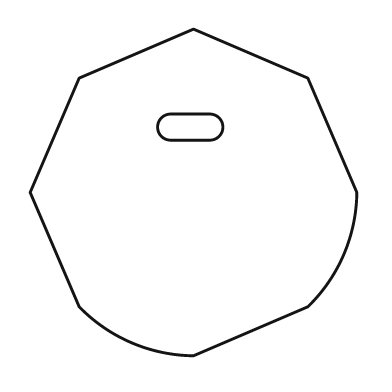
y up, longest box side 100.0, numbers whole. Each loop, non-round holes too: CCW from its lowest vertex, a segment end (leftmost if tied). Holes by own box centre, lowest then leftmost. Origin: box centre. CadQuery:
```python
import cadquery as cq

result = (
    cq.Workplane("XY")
    .moveTo(0.0, -50.0)
    .lineTo(35.0, -35.0)
    .threePointArc((46.0, -19.0), (50.0, 0.0))
    .lineTo(35.0, 35.0)
    .lineTo(0.0, 50.0)
    .lineTo(-35.0, 35.0)
    .lineTo(-50.0, 0.0)
    .lineTo(-35.0, -35.0)
    .threePointArc((-19.0, -46.0), (0.0, -50.0))
    .close()
    .moveTo(-7.0, 16.0)
    .lineTo(5.0, 16.0)
    .threePointArc((9.0, 20.0), (5.0, 24.0))
    .lineTo(-7.0, 24.0)
    .threePointArc((-11.0, 20.0), (-7.0, 16.0))
    .close()
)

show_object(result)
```